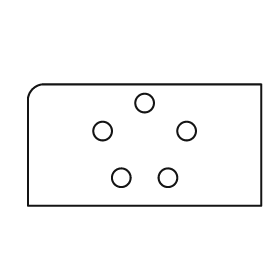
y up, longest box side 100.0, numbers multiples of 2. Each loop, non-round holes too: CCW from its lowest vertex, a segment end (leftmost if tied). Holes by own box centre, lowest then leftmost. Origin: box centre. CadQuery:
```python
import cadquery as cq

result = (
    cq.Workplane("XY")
    .moveTo(-50.0, -26.0)
    .lineTo(50.0, -26.0)
    .lineTo(50.0, 26.0)
    .lineTo(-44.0, 26.0)
    .threePointArc((-48.0, 24.0), (-50.0, 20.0))
    .close()
    .moveTo(-10.0, -14.0)
    .circle(4.0)
    .moveTo(10.0, -14.0)
    .circle(4.0)
    .moveTo(-18.0, 6.0)
    .circle(4.0)
    .moveTo(18.0, 6.0)
    .circle(4.0)
    .moveTo(0.0, 18.0)
    .circle(4.0)
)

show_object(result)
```